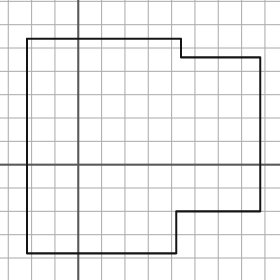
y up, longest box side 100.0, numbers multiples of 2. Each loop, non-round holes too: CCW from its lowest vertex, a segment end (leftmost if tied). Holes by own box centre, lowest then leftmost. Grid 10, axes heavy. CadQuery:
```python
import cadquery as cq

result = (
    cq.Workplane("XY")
    .moveTo(-22.0, -38.0)
    .lineTo(42.0, -38.0)
    .lineTo(42.0, -20.0)
    .lineTo(78.0, -20.0)
    .lineTo(78.0, 46.0)
    .lineTo(44.0, 46.0)
    .lineTo(44.0, 54.0)
    .lineTo(-22.0, 54.0)
    .close()
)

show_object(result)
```